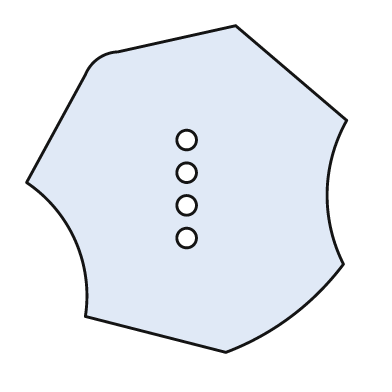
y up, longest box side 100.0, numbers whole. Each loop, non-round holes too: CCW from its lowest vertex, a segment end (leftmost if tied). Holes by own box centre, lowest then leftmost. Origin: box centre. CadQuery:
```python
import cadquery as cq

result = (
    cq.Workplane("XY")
    .moveTo(12.0, -50.0)
    .threePointArc((32.0, -39.0), (48.0, -23.0))
    .threePointArc((43.0, -1.0), (49.0, 21.0))
    .lineTo(15.0, 50.0)
    .lineTo(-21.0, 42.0)
    .threePointArc((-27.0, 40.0), (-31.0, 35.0))
    .lineTo(-49.0, 2.0)
    .threePointArc((-34.0, -16.0), (-31.0, -39.0))
    .close()
    .moveTo(0.0, -15.0)
    .circle(3.0)
    .moveTo(0.0, -5.0)
    .circle(3.0)
    .moveTo(0.0, 5.0)
    .circle(3.0)
    .moveTo(0.0, 15.0)
    .circle(3.0)
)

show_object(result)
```